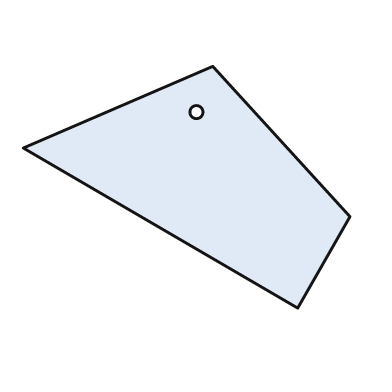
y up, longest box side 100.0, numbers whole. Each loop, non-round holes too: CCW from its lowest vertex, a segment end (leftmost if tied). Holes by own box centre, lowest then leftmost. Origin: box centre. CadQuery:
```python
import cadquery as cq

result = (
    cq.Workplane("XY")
    .moveTo(34.0, -37.0)
    .lineTo(50.0, -9.0)
    .lineTo(8.0, 37.0)
    .lineTo(-50.0, 12.0)
    .close()
    .moveTo(3.0, 23.0)
    .circle(2.0)
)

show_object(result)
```